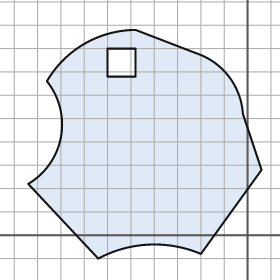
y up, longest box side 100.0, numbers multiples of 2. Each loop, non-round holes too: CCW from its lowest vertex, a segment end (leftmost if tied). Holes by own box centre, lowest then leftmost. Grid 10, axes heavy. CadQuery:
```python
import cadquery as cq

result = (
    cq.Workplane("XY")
    .moveTo(-64.0, -10.0)
    .threePointArc((-42.0, -4.0), (-20.0, -8.0))
    .lineTo(6.0, 28.0)
    .lineTo(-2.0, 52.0)
    .threePointArc((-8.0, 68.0), (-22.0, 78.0))
    .lineTo(-48.0, 88.0)
    .threePointArc((-70.0, 82.0), (-86.0, 66.0))
    .threePointArc((-80.0, 42.0), (-94.0, 22.0))
    .close()
    .moveTo(-60.0, 68.0)
    .lineTo(-48.0, 68.0)
    .lineTo(-48.0, 80.0)
    .lineTo(-60.0, 80.0)
    .close()
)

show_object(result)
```